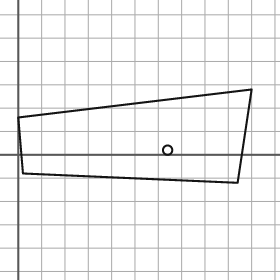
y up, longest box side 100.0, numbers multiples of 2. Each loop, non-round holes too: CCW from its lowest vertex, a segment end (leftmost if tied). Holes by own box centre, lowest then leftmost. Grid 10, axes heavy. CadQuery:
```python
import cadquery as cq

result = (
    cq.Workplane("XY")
    .moveTo(94.0, -12.0)
    .lineTo(100.0, 28.0)
    .lineTo(0.0, 16.0)
    .lineTo(2.0, -8.0)
    .close()
    .moveTo(64.0, 2.0)
    .circle(2.0)
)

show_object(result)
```